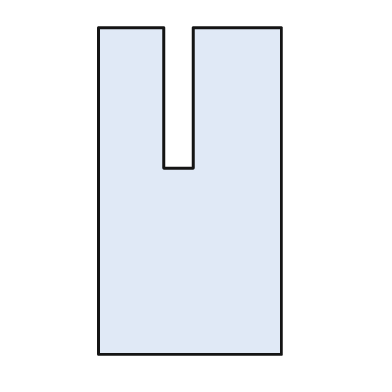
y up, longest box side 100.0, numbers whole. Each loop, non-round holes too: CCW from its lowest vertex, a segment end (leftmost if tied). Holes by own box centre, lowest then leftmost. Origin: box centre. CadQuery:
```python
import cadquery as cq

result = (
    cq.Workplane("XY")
    .moveTo(-28.0, -50.0)
    .lineTo(28.0, -50.0)
    .lineTo(28.0, 50.0)
    .lineTo(1.0, 50.0)
    .lineTo(1.0, 7.0)
    .lineTo(-8.0, 7.0)
    .lineTo(-8.0, 50.0)
    .lineTo(-28.0, 50.0)
    .close()
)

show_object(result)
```